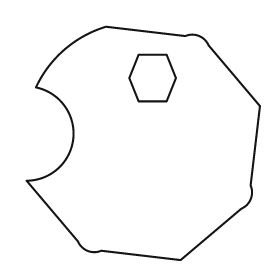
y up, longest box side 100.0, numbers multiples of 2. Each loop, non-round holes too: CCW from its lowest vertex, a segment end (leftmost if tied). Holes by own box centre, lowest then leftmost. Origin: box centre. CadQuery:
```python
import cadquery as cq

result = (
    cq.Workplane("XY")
    .moveTo(16.0, -50.0)
    .lineTo(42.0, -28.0)
    .threePointArc((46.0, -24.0), (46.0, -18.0))
    .lineTo(50.0, 16.0)
    .lineTo(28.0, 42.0)
    .threePointArc((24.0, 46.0), (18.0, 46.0))
    .lineTo(-16.0, 50.0)
    .threePointArc((-34.0, 40.0), (-46.0, 24.0))
    .threePointArc((-30.0, 2.0), (-50.0, -16.0))
    .lineTo(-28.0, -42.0)
    .threePointArc((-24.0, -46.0), (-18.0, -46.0))
    .close()
    .moveTo(-2.0, 18.0)
    .lineTo(10.0, 18.0)
    .lineTo(14.0, 28.0)
    .lineTo(10.0, 38.0)
    .lineTo(-2.0, 38.0)
    .lineTo(-6.0, 28.0)
    .close()
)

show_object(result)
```